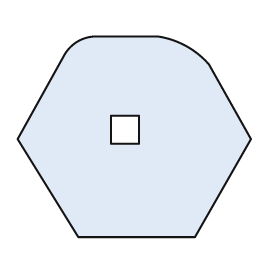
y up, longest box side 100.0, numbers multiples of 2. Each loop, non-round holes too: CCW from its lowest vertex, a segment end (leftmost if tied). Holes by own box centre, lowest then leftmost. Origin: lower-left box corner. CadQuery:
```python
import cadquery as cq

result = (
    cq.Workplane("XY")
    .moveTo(26.0, 0.0)
    .lineTo(76.0, 0.0)
    .lineTo(100.0, 42.0)
    .lineTo(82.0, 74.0)
    .threePointArc((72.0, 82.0), (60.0, 86.0))
    .lineTo(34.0, 86.0)
    .threePointArc((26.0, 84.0), (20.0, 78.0))
    .lineTo(0.0, 42.0)
    .close()
    .moveTo(40.0, 40.0)
    .lineTo(52.0, 40.0)
    .lineTo(52.0, 52.0)
    .lineTo(40.0, 52.0)
    .close()
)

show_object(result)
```